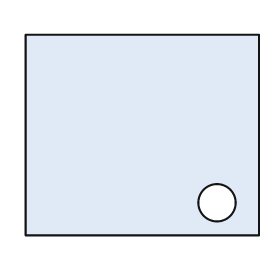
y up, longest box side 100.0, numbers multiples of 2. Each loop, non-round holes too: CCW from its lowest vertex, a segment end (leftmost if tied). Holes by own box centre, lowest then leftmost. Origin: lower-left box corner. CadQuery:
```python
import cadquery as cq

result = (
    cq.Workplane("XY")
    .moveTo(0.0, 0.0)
    .lineTo(100.0, 0.0)
    .lineTo(100.0, 86.0)
    .lineTo(0.0, 86.0)
    .close()
    .moveTo(82.0, 14.0)
    .circle(8.0)
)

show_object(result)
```